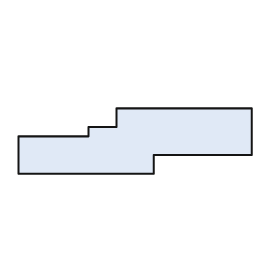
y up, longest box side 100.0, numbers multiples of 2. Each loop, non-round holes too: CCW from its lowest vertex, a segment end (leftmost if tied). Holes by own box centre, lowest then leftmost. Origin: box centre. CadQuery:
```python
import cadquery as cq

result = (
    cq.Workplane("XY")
    .moveTo(-50.0, -14.0)
    .lineTo(8.0, -14.0)
    .lineTo(8.0, -6.0)
    .lineTo(50.0, -6.0)
    .lineTo(50.0, 14.0)
    .lineTo(-8.0, 14.0)
    .lineTo(-8.0, 6.0)
    .lineTo(-20.0, 6.0)
    .lineTo(-20.0, 2.0)
    .lineTo(-50.0, 2.0)
    .close()
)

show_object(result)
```